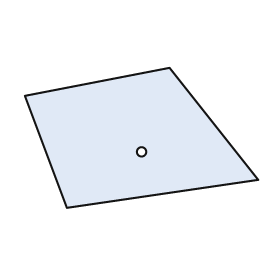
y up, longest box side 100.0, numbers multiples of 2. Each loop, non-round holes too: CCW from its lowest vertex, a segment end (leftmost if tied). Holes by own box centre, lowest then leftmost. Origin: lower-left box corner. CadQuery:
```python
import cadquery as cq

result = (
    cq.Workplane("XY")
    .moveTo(18.0, 0.0)
    .lineTo(100.0, 12.0)
    .lineTo(62.0, 60.0)
    .lineTo(0.0, 48.0)
    .close()
    .moveTo(50.0, 24.0)
    .circle(2.0)
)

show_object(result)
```